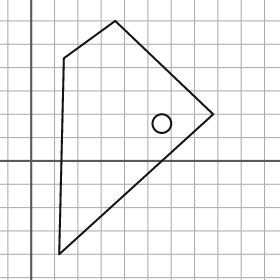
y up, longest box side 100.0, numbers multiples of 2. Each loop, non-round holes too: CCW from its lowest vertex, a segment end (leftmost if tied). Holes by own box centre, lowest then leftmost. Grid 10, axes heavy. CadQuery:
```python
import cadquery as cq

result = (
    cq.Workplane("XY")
    .moveTo(12.0, -40.0)
    .lineTo(78.0, 20.0)
    .lineTo(36.0, 60.0)
    .lineTo(14.0, 44.0)
    .close()
    .moveTo(56.0, 16.0)
    .circle(4.0)
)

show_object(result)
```